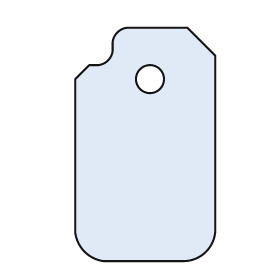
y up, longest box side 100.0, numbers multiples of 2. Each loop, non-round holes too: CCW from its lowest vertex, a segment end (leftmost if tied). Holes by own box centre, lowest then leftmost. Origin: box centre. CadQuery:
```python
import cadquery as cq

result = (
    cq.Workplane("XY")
    .moveTo(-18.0, -50.0)
    .lineTo(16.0, -50.0)
    .threePointArc((26.0, -46.0), (30.0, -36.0))
    .lineTo(30.0, 38.0)
    .lineTo(18.0, 50.0)
    .lineTo(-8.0, 50.0)
    .threePointArc((-12.0, 48.0), (-14.0, 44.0))
    .lineTo(-14.0, 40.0)
    .threePointArc((-16.0, 36.0), (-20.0, 34.0))
    .lineTo(-24.0, 34.0)
    .lineTo(-30.0, 28.0)
    .lineTo(-30.0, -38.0)
    .threePointArc((-26.0, -46.0), (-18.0, -50.0))
    .close()
    .moveTo(2.0, 28.0)
    .circle(6.0)
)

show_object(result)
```